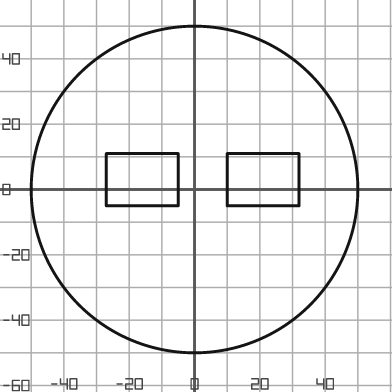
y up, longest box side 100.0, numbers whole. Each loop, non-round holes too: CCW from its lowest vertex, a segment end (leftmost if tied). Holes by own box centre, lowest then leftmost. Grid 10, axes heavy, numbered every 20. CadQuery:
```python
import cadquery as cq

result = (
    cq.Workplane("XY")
    .moveTo(0.0, 0.0)
    .circle(50.0)
    .moveTo(-27.0, -5.0)
    .lineTo(-5.0, -5.0)
    .lineTo(-5.0, 11.0)
    .lineTo(-27.0, 11.0)
    .close()
    .moveTo(10.0, -5.0)
    .lineTo(32.0, -5.0)
    .lineTo(32.0, 11.0)
    .lineTo(10.0, 11.0)
    .close()
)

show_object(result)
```